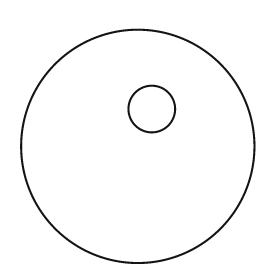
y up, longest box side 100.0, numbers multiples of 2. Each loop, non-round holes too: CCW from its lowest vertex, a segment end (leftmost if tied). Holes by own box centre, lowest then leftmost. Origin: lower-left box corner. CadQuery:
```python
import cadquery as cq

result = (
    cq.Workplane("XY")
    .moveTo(50.0, 50.0)
    .circle(50.0)
    .moveTo(56.0, 66.0)
    .circle(10.0)
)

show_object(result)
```